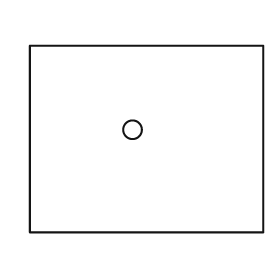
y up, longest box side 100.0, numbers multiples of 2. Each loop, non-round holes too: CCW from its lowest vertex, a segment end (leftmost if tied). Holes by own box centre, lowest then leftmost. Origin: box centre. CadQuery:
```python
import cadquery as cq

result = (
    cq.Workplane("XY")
    .moveTo(-50.0, -40.0)
    .lineTo(50.0, -40.0)
    .lineTo(50.0, 40.0)
    .lineTo(-50.0, 40.0)
    .close()
    .moveTo(-6.0, 4.0)
    .circle(4.0)
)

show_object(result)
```